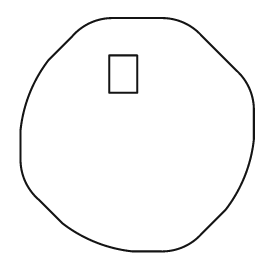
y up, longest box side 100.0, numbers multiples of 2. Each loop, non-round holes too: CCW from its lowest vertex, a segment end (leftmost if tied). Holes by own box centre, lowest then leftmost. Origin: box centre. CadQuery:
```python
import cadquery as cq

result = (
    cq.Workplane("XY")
    .moveTo(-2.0, -50.0)
    .lineTo(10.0, -50.0)
    .threePointArc((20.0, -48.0), (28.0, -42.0))
    .lineTo(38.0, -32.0)
    .threePointArc((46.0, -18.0), (50.0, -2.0))
    .lineTo(50.0, 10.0)
    .threePointArc((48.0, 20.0), (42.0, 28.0))
    .lineTo(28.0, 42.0)
    .threePointArc((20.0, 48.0), (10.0, 50.0))
    .lineTo(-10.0, 50.0)
    .threePointArc((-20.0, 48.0), (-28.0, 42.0))
    .lineTo(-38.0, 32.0)
    .threePointArc((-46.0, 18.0), (-50.0, 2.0))
    .lineTo(-50.0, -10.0)
    .threePointArc((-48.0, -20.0), (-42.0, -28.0))
    .lineTo(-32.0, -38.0)
    .threePointArc((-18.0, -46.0), (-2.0, -50.0))
    .close()
    .moveTo(-12.0, 18.0)
    .lineTo(0.0, 18.0)
    .lineTo(0.0, 34.0)
    .lineTo(-12.0, 34.0)
    .close()
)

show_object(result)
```